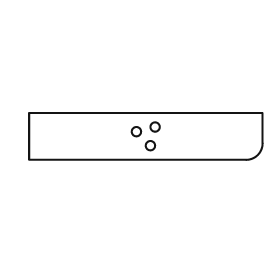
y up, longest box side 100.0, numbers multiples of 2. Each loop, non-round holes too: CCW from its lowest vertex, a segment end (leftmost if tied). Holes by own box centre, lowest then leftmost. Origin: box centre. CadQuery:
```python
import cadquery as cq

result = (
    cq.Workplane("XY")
    .moveTo(-50.0, -10.0)
    .lineTo(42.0, -10.0)
    .threePointArc((48.0, -8.0), (50.0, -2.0))
    .lineTo(50.0, 10.0)
    .lineTo(-50.0, 10.0)
    .close()
    .moveTo(2.0, -4.0)
    .circle(2.0)
    .moveTo(-4.0, 2.0)
    .circle(2.0)
    .moveTo(4.0, 4.0)
    .circle(2.0)
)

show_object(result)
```